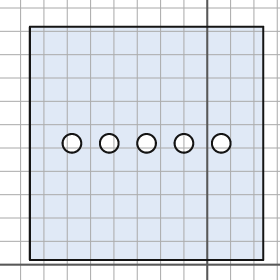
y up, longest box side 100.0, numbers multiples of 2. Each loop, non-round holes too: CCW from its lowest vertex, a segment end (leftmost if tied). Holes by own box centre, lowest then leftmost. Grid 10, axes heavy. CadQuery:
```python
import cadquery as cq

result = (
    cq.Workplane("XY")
    .moveTo(-76.0, 2.0)
    .lineTo(24.0, 2.0)
    .lineTo(24.0, 102.0)
    .lineTo(-76.0, 102.0)
    .close()
    .moveTo(-58.0, 52.0)
    .circle(4.0)
    .moveTo(-42.0, 52.0)
    .circle(4.0)
    .moveTo(-26.0, 52.0)
    .circle(4.0)
    .moveTo(-10.0, 52.0)
    .circle(4.0)
    .moveTo(6.0, 52.0)
    .circle(4.0)
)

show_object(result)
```